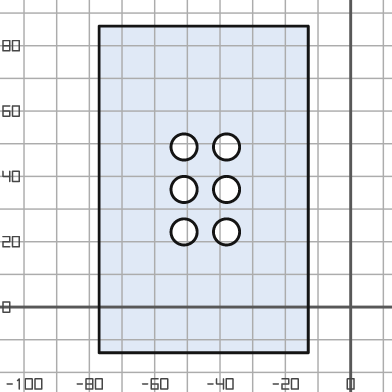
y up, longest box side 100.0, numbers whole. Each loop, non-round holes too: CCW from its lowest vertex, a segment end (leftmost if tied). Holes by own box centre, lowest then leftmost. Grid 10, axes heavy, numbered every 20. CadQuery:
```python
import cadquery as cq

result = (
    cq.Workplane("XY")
    .moveTo(-77.0, -14.0)
    .lineTo(-13.0, -14.0)
    .lineTo(-13.0, 86.0)
    .lineTo(-77.0, 86.0)
    .close()
    .moveTo(-51.0, 23.0)
    .circle(4.0)
    .moveTo(-38.0, 23.0)
    .circle(4.0)
    .moveTo(-51.0, 36.0)
    .circle(4.0)
    .moveTo(-38.0, 36.0)
    .circle(4.0)
    .moveTo(-51.0, 49.0)
    .circle(4.0)
    .moveTo(-38.0, 49.0)
    .circle(4.0)
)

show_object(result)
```